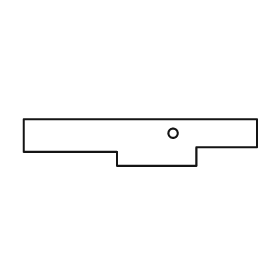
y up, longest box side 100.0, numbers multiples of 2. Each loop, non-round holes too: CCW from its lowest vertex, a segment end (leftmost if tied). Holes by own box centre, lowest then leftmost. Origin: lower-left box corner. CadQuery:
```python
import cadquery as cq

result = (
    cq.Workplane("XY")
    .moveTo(40.0, 0.0)
    .lineTo(74.0, 0.0)
    .lineTo(74.0, 8.0)
    .lineTo(100.0, 8.0)
    .lineTo(100.0, 20.0)
    .lineTo(0.0, 20.0)
    .lineTo(0.0, 6.0)
    .lineTo(40.0, 6.0)
    .close()
    .moveTo(64.0, 14.0)
    .circle(2.0)
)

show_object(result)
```